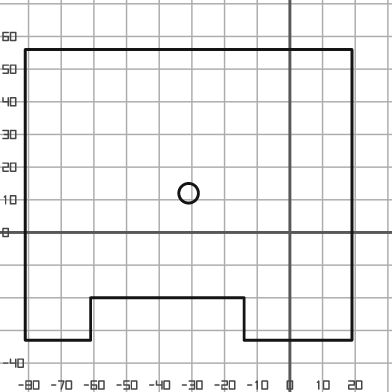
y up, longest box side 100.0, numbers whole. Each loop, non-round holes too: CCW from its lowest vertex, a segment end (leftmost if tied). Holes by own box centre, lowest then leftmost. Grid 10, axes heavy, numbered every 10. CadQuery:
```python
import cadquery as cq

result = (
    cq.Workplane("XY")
    .moveTo(-81.0, -33.0)
    .lineTo(-61.0, -33.0)
    .lineTo(-61.0, -20.0)
    .lineTo(-14.0, -20.0)
    .lineTo(-14.0, -33.0)
    .lineTo(19.0, -33.0)
    .lineTo(19.0, 56.0)
    .lineTo(-81.0, 56.0)
    .close()
    .moveTo(-31.0, 12.0)
    .circle(3.0)
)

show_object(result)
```